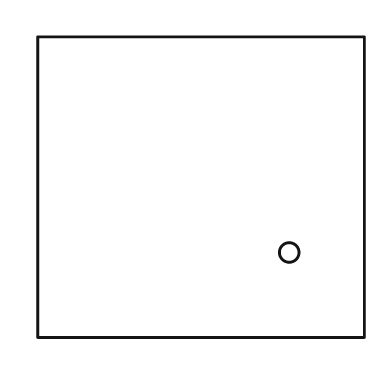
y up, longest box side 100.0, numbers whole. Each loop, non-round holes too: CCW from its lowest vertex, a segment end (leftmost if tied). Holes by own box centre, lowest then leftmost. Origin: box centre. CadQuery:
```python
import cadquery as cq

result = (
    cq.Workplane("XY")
    .moveTo(-50.0, -46.0)
    .lineTo(50.0, -46.0)
    .lineTo(50.0, 46.0)
    .lineTo(-50.0, 46.0)
    .close()
    .moveTo(27.0, -20.0)
    .circle(3.0)
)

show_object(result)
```